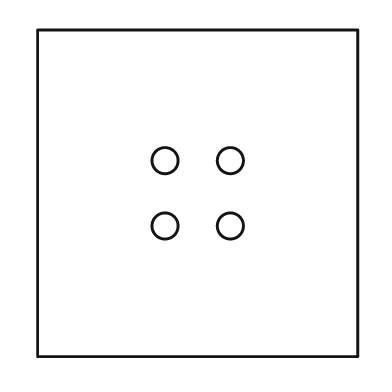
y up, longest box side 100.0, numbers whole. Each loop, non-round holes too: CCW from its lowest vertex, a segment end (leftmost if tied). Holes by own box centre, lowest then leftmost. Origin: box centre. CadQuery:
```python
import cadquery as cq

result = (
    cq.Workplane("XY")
    .moveTo(-49.0, -50.0)
    .lineTo(49.0, -50.0)
    .lineTo(49.0, 50.0)
    .lineTo(-49.0, 50.0)
    .close()
    .moveTo(-10.0, -10.0)
    .circle(4.0)
    .moveTo(10.0, -10.0)
    .circle(4.0)
    .moveTo(-10.0, 10.0)
    .circle(4.0)
    .moveTo(10.0, 10.0)
    .circle(4.0)
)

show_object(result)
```